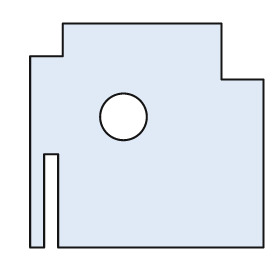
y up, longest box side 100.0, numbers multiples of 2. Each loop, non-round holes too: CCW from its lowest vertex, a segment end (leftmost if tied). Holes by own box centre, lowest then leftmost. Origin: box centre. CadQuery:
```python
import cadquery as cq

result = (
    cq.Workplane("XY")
    .moveTo(-50.0, -48.0)
    .lineTo(-44.0, -48.0)
    .lineTo(-44.0, -8.0)
    .lineTo(-38.0, -8.0)
    .lineTo(-38.0, -48.0)
    .lineTo(50.0, -48.0)
    .lineTo(50.0, 24.0)
    .lineTo(32.0, 24.0)
    .lineTo(32.0, 48.0)
    .lineTo(-36.0, 48.0)
    .lineTo(-36.0, 34.0)
    .lineTo(-50.0, 34.0)
    .close()
    .moveTo(-10.0, 8.0)
    .circle(10.0)
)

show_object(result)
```